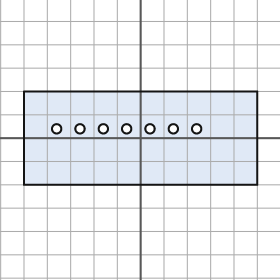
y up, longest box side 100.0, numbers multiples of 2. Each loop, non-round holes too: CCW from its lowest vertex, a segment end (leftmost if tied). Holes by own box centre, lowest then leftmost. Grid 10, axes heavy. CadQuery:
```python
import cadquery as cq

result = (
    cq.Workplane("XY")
    .moveTo(-50.0, -20.0)
    .lineTo(50.0, -20.0)
    .lineTo(50.0, 20.0)
    .lineTo(-50.0, 20.0)
    .close()
    .moveTo(-36.0, 4.0)
    .circle(2.0)
    .moveTo(-26.0, 4.0)
    .circle(2.0)
    .moveTo(-16.0, 4.0)
    .circle(2.0)
    .moveTo(-6.0, 4.0)
    .circle(2.0)
    .moveTo(4.0, 4.0)
    .circle(2.0)
    .moveTo(14.0, 4.0)
    .circle(2.0)
    .moveTo(24.0, 4.0)
    .circle(2.0)
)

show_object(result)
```